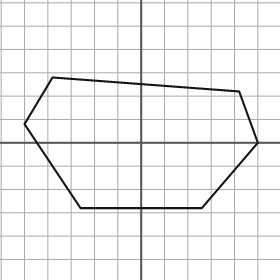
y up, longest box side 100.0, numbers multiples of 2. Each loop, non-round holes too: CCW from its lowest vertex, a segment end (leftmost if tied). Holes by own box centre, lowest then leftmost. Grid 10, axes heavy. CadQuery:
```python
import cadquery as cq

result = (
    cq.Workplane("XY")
    .moveTo(-26.0, -28.0)
    .lineTo(26.0, -28.0)
    .lineTo(50.0, 0.0)
    .lineTo(42.0, 22.0)
    .lineTo(-38.0, 28.0)
    .lineTo(-50.0, 8.0)
    .close()
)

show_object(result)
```